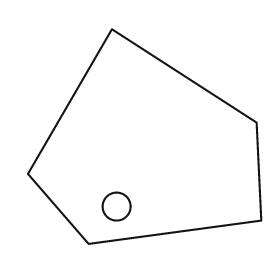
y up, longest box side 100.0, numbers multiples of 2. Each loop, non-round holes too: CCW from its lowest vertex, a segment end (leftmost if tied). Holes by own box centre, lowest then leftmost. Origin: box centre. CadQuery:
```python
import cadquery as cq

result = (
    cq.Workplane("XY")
    .moveTo(-24.0, -46.0)
    .lineTo(50.0, -36.0)
    .lineTo(48.0, 6.0)
    .lineTo(-14.0, 46.0)
    .lineTo(-50.0, -16.0)
    .close()
    .moveTo(-12.0, -30.0)
    .circle(6.0)
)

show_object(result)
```